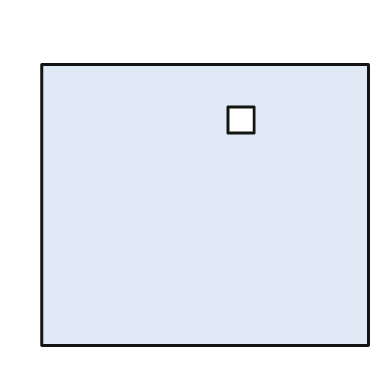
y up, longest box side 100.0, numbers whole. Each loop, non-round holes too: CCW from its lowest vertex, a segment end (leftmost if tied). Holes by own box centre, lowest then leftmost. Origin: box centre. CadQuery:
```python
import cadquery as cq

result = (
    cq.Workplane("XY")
    .moveTo(-50.0, -43.0)
    .lineTo(50.0, -43.0)
    .lineTo(50.0, 43.0)
    .lineTo(-50.0, 43.0)
    .close()
    .moveTo(7.0, 22.0)
    .lineTo(15.0, 22.0)
    .lineTo(15.0, 30.0)
    .lineTo(7.0, 30.0)
    .close()
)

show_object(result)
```